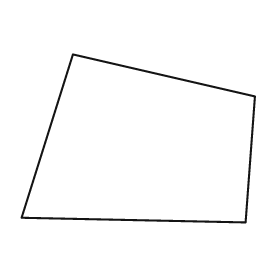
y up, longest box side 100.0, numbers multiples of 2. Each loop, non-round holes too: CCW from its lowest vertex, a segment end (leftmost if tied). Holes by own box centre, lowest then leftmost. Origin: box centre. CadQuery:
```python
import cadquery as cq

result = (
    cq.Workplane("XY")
    .moveTo(46.0, -36.0)
    .lineTo(50.0, 18.0)
    .lineTo(-28.0, 36.0)
    .lineTo(-50.0, -34.0)
    .close()
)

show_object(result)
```